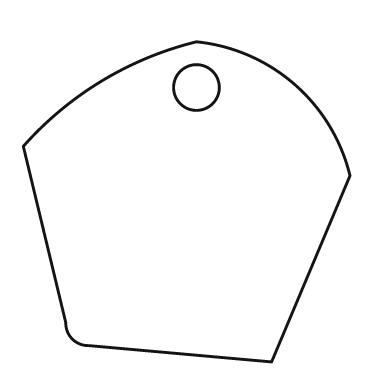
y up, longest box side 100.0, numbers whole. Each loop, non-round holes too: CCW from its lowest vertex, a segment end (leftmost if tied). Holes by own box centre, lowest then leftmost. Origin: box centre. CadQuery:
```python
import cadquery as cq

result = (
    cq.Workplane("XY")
    .moveTo(26.0, -49.0)
    .lineTo(50.0, 8.0)
    .threePointArc((33.0, 36.0), (3.0, 49.0))
    .threePointArc((-26.0, 37.0), (-50.0, 17.0))
    .lineTo(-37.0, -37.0)
    .threePointArc((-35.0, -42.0), (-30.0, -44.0))
    .close()
    .moveTo(3.0, 35.0)
    .circle(7.0)
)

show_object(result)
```